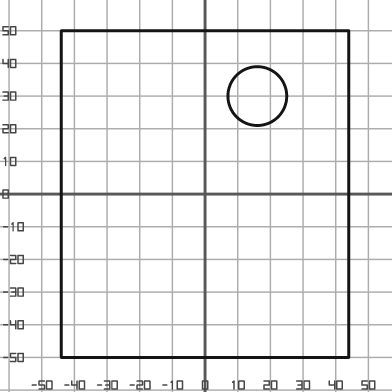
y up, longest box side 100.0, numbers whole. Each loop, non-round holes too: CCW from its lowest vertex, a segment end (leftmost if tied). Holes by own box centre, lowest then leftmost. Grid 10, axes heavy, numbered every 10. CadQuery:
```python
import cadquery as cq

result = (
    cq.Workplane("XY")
    .moveTo(-44.0, -50.0)
    .lineTo(44.0, -50.0)
    .lineTo(44.0, 50.0)
    .lineTo(-44.0, 50.0)
    .close()
    .moveTo(16.0, 30.0)
    .circle(9.0)
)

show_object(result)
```